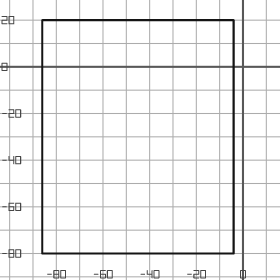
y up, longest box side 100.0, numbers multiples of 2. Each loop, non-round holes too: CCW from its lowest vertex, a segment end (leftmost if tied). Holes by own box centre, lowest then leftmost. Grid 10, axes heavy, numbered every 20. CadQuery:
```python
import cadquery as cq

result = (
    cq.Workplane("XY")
    .moveTo(-86.0, -80.0)
    .lineTo(-4.0, -80.0)
    .lineTo(-4.0, 20.0)
    .lineTo(-86.0, 20.0)
    .close()
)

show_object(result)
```